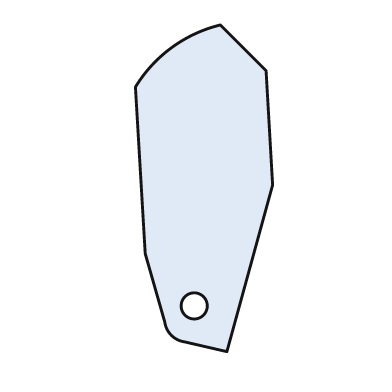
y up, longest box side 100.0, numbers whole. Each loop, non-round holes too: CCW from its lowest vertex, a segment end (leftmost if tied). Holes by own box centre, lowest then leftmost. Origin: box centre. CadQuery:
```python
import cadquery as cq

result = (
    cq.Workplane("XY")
    .moveTo(7.0, -50.0)
    .lineTo(21.0, 1.0)
    .lineTo(19.0, 36.0)
    .lineTo(5.0, 50.0)
    .threePointArc((-10.0, 43.0), (-21.0, 31.0))
    .lineTo(-18.0, -20.0)
    .lineTo(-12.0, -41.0)
    .threePointArc((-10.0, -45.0), (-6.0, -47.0))
    .close()
    .moveTo(-3.0, -36.0)
    .circle(4.0)
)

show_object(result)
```